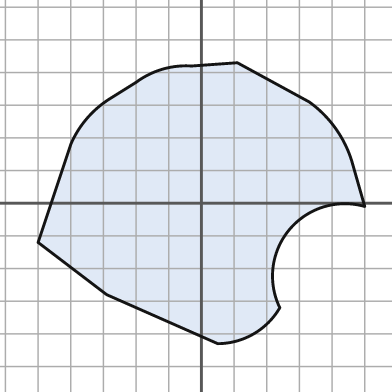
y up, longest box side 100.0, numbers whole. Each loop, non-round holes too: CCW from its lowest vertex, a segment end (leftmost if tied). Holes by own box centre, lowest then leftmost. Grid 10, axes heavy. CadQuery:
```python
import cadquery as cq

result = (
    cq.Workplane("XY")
    .moveTo(5.0, -43.0)
    .threePointArc((16.0, -40.0), (24.0, -32.0))
    .threePointArc((27.0, -8.0), (50.0, -1.0))
    .lineTo(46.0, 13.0)
    .threePointArc((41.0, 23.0), (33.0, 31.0))
    .lineTo(11.0, 43.0)
    .lineTo(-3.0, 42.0)
    .threePointArc((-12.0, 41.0), (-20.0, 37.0))
    .lineTo(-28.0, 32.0)
    .threePointArc((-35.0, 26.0), (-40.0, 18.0))
    .lineTo(-50.0, -12.0)
    .lineTo(-29.0, -28.0)
    .close()
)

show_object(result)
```